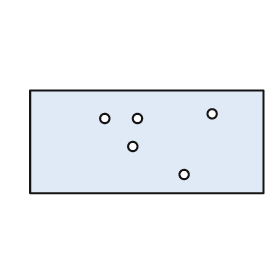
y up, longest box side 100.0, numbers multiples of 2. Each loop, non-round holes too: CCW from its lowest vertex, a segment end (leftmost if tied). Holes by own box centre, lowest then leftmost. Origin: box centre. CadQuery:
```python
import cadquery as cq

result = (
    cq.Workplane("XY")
    .moveTo(-50.0, -22.0)
    .lineTo(50.0, -22.0)
    .lineTo(50.0, 22.0)
    .lineTo(-50.0, 22.0)
    .close()
    .moveTo(16.0, -14.0)
    .circle(2.0)
    .moveTo(-6.0, -2.0)
    .circle(2.0)
    .moveTo(-18.0, 10.0)
    .circle(2.0)
    .moveTo(-4.0, 10.0)
    .circle(2.0)
    .moveTo(28.0, 12.0)
    .circle(2.0)
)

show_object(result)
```